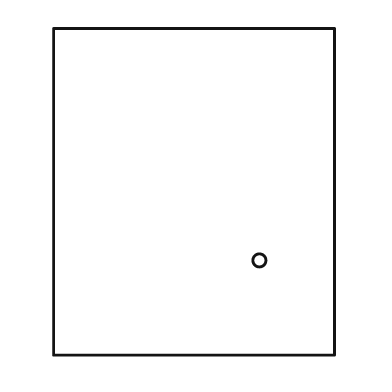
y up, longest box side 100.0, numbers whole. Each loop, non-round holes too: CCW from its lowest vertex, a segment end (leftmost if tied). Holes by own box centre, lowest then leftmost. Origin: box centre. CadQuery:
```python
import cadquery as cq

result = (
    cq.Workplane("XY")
    .moveTo(-43.0, -50.0)
    .lineTo(43.0, -50.0)
    .lineTo(43.0, 50.0)
    .lineTo(-43.0, 50.0)
    .close()
    .moveTo(20.0, -21.0)
    .circle(2.0)
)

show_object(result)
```